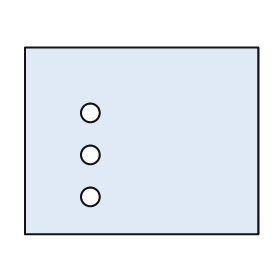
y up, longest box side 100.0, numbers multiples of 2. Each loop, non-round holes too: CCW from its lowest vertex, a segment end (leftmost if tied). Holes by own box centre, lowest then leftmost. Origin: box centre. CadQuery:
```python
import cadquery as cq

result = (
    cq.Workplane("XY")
    .moveTo(-50.0, -40.0)
    .lineTo(50.0, -40.0)
    .lineTo(50.0, 40.0)
    .lineTo(-50.0, 40.0)
    .close()
    .moveTo(-22.0, -24.0)
    .circle(4.0)
    .moveTo(-22.0, -6.0)
    .circle(4.0)
    .moveTo(-22.0, 12.0)
    .circle(4.0)
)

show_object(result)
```